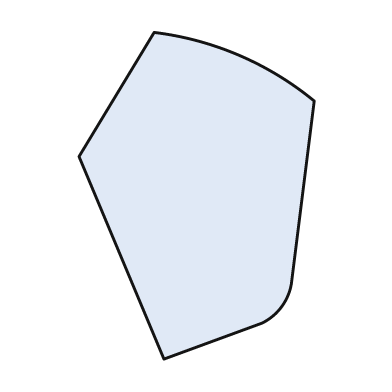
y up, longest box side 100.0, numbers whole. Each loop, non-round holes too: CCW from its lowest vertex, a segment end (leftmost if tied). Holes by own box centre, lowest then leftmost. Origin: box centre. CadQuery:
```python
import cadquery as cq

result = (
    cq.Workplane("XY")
    .moveTo(-10.0, -50.0)
    .lineTo(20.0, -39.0)
    .threePointArc((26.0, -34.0), (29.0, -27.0))
    .lineTo(36.0, 29.0)
    .threePointArc((13.0, 43.0), (-13.0, 50.0))
    .lineTo(-36.0, 12.0)
    .close()
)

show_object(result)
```